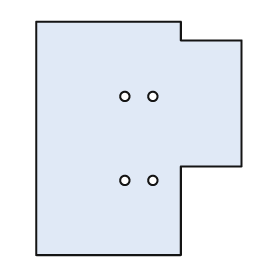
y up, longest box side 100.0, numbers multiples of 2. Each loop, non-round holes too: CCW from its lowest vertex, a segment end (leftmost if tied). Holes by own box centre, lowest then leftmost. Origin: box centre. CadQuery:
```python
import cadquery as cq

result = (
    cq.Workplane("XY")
    .moveTo(-44.0, -50.0)
    .lineTo(18.0, -50.0)
    .lineTo(18.0, -12.0)
    .lineTo(44.0, -12.0)
    .lineTo(44.0, 42.0)
    .lineTo(18.0, 42.0)
    .lineTo(18.0, 50.0)
    .lineTo(-44.0, 50.0)
    .close()
    .moveTo(-6.0, -18.0)
    .circle(2.0)
    .moveTo(6.0, -18.0)
    .circle(2.0)
    .moveTo(-6.0, 18.0)
    .circle(2.0)
    .moveTo(6.0, 18.0)
    .circle(2.0)
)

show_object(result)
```